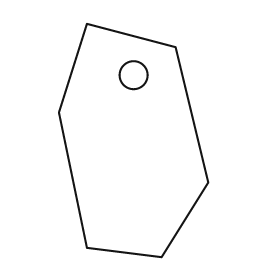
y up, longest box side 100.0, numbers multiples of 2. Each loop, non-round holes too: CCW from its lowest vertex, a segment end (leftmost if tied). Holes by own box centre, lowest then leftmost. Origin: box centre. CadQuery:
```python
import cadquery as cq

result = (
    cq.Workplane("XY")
    .moveTo(12.0, -50.0)
    .lineTo(32.0, -18.0)
    .lineTo(18.0, 40.0)
    .lineTo(-20.0, 50.0)
    .lineTo(-32.0, 12.0)
    .lineTo(-20.0, -46.0)
    .close()
    .moveTo(0.0, 28.0)
    .circle(6.0)
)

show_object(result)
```